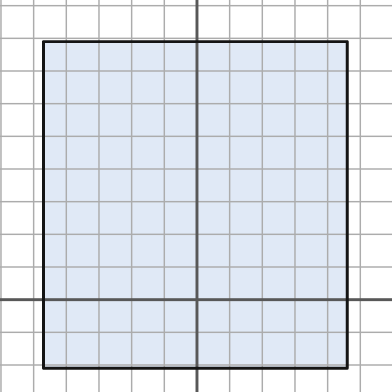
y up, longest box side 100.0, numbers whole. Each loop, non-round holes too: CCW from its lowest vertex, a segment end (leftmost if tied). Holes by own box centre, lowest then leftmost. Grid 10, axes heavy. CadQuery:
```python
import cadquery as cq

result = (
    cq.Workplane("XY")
    .moveTo(-47.0, -21.0)
    .lineTo(46.0, -21.0)
    .lineTo(46.0, 79.0)
    .lineTo(-47.0, 79.0)
    .close()
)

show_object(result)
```